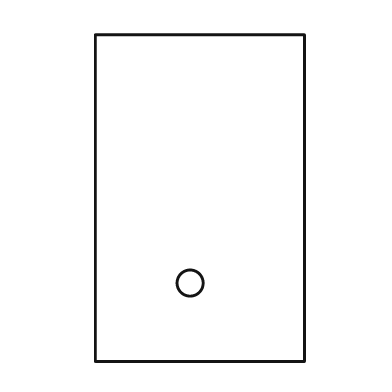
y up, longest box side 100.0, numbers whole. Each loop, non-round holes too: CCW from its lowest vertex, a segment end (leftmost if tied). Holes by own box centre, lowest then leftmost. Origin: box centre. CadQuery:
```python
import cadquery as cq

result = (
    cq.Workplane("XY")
    .moveTo(-32.0, -50.0)
    .lineTo(32.0, -50.0)
    .lineTo(32.0, 50.0)
    .lineTo(-32.0, 50.0)
    .close()
    .moveTo(-3.0, -26.0)
    .circle(4.0)
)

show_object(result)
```